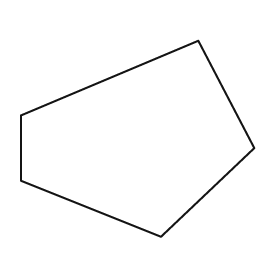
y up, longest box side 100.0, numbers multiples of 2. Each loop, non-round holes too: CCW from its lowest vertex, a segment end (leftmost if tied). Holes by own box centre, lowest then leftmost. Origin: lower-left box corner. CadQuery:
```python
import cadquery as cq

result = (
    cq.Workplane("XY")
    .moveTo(60.0, 0.0)
    .lineTo(100.0, 38.0)
    .lineTo(76.0, 84.0)
    .lineTo(0.0, 52.0)
    .lineTo(0.0, 24.0)
    .close()
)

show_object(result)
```